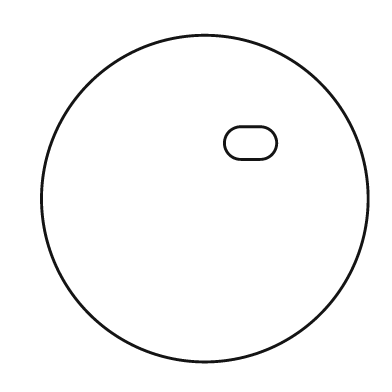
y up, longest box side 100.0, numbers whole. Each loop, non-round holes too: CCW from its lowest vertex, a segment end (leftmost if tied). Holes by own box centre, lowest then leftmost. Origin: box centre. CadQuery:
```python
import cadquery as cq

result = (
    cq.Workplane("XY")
    .moveTo(0.0, 0.0)
    .circle(50.0)
    .moveTo(11.0, 12.0)
    .lineTo(17.0, 12.0)
    .threePointArc((22.0, 17.0), (17.0, 22.0))
    .lineTo(11.0, 22.0)
    .threePointArc((6.0, 17.0), (11.0, 12.0))
    .close()
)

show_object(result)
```